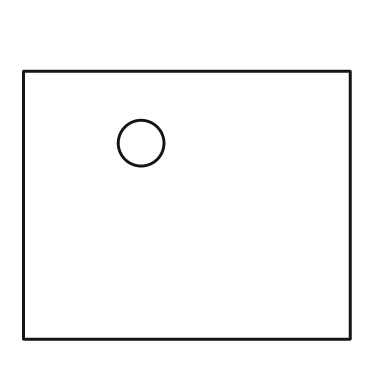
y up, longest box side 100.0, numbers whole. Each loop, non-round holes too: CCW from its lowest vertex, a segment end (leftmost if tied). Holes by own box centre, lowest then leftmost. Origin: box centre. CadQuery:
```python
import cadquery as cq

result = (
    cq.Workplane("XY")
    .moveTo(-50.0, -41.0)
    .lineTo(50.0, -41.0)
    .lineTo(50.0, 41.0)
    .lineTo(-50.0, 41.0)
    .close()
    .moveTo(-14.0, 19.0)
    .circle(7.0)
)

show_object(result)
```